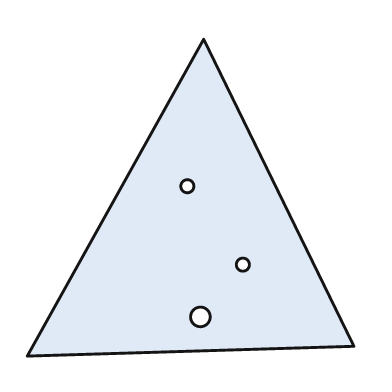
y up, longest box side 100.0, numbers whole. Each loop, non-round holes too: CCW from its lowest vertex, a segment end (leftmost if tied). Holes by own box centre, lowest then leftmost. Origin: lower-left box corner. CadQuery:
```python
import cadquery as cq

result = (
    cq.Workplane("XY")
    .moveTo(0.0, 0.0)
    .lineTo(100.0, 3.0)
    .lineTo(54.0, 97.0)
    .close()
    .moveTo(53.0, 12.0)
    .circle(3.0)
    .moveTo(66.0, 28.0)
    .circle(2.0)
    .moveTo(49.0, 52.0)
    .circle(2.0)
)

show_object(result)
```